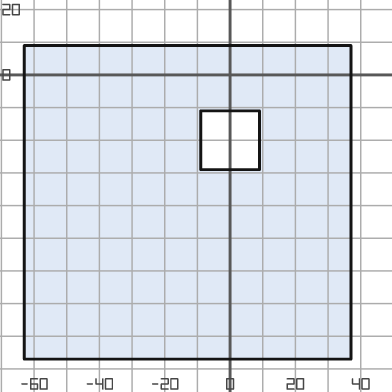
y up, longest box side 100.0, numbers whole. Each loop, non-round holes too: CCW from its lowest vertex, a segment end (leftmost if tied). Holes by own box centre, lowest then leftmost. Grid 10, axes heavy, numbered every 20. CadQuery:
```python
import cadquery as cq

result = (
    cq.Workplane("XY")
    .moveTo(-63.0, -87.0)
    .lineTo(37.0, -87.0)
    .lineTo(37.0, 9.0)
    .lineTo(-63.0, 9.0)
    .close()
    .moveTo(-9.0, -29.0)
    .lineTo(9.0, -29.0)
    .lineTo(9.0, -11.0)
    .lineTo(-9.0, -11.0)
    .close()
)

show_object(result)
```